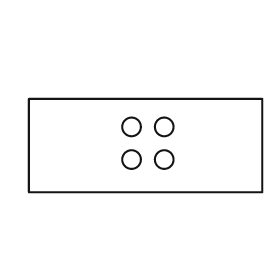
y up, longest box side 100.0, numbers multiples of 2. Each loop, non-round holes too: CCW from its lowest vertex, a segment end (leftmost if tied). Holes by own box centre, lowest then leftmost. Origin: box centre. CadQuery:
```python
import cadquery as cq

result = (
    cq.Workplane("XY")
    .moveTo(-50.0, -20.0)
    .lineTo(50.0, -20.0)
    .lineTo(50.0, 20.0)
    .lineTo(-50.0, 20.0)
    .close()
    .moveTo(-6.0, -6.0)
    .circle(4.0)
    .moveTo(8.0, -6.0)
    .circle(4.0)
    .moveTo(-6.0, 8.0)
    .circle(4.0)
    .moveTo(8.0, 8.0)
    .circle(4.0)
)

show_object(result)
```